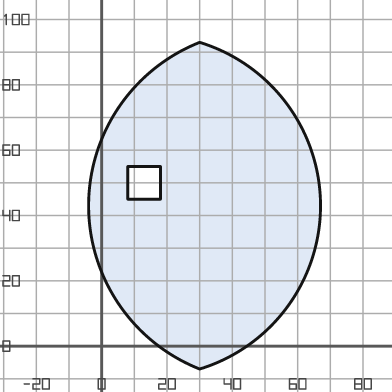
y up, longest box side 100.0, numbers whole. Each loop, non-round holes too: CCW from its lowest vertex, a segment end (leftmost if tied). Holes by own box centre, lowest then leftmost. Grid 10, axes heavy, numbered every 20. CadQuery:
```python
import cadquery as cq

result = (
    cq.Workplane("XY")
    .moveTo(30.0, -7.0)
    .threePointArc((67.0, 43.0), (30.0, 93.0))
    .threePointArc((-4.0, 43.0), (30.0, -7.0))
    .close()
    .moveTo(8.0, 45.0)
    .lineTo(18.0, 45.0)
    .lineTo(18.0, 55.0)
    .lineTo(8.0, 55.0)
    .close()
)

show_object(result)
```